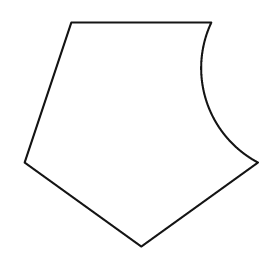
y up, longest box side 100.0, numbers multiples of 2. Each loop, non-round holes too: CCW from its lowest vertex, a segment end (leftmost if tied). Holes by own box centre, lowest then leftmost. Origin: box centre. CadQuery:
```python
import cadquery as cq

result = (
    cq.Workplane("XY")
    .moveTo(0.0, -48.0)
    .lineTo(50.0, -12.0)
    .threePointArc((28.0, 14.0), (30.0, 48.0))
    .lineTo(-30.0, 48.0)
    .lineTo(-50.0, -12.0)
    .close()
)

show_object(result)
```